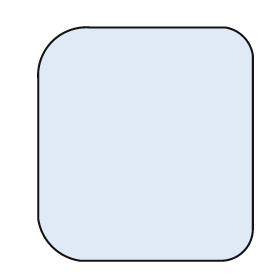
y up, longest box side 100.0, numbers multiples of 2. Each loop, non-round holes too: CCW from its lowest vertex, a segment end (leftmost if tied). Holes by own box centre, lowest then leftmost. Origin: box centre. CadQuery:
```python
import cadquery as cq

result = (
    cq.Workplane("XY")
    .moveTo(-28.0, -50.0)
    .lineTo(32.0, -50.0)
    .threePointArc((42.0, -46.0), (46.0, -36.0))
    .lineTo(46.0, 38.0)
    .threePointArc((42.0, 46.0), (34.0, 50.0))
    .lineTo(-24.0, 50.0)
    .threePointArc((-40.0, 44.0), (-46.0, 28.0))
    .lineTo(-46.0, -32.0)
    .threePointArc((-40.0, -44.0), (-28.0, -50.0))
    .close()
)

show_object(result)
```